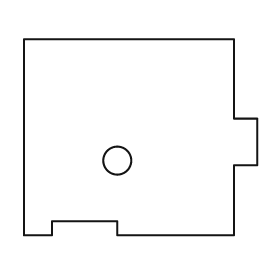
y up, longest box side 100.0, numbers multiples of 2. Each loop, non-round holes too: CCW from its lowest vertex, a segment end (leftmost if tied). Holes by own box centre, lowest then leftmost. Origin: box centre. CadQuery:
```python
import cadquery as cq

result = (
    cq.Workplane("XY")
    .moveTo(-50.0, -42.0)
    .lineTo(-38.0, -42.0)
    .lineTo(-38.0, -36.0)
    .lineTo(-10.0, -36.0)
    .lineTo(-10.0, -42.0)
    .lineTo(40.0, -42.0)
    .lineTo(40.0, -12.0)
    .lineTo(50.0, -12.0)
    .lineTo(50.0, 8.0)
    .lineTo(40.0, 8.0)
    .lineTo(40.0, 42.0)
    .lineTo(-50.0, 42.0)
    .close()
    .moveTo(-10.0, -10.0)
    .circle(6.0)
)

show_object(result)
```